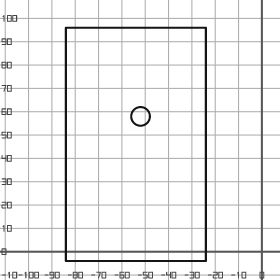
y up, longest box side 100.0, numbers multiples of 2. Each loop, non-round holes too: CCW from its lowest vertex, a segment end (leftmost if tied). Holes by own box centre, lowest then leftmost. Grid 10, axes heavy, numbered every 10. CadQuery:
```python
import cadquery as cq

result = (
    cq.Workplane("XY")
    .moveTo(-84.0, -4.0)
    .lineTo(-24.0, -4.0)
    .lineTo(-24.0, 96.0)
    .lineTo(-84.0, 96.0)
    .close()
    .moveTo(-52.0, 58.0)
    .circle(4.0)
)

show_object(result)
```